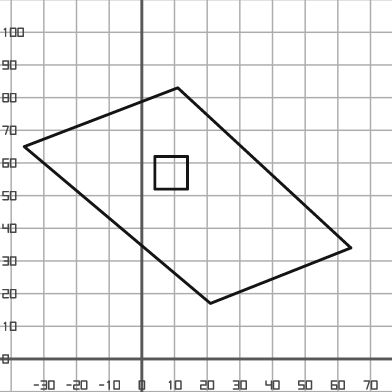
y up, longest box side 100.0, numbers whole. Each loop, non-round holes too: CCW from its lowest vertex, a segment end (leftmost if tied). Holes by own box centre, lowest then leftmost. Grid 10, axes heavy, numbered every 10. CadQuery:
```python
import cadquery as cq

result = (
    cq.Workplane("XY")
    .moveTo(21.0, 17.0)
    .lineTo(64.0, 34.0)
    .lineTo(11.0, 83.0)
    .lineTo(-36.0, 65.0)
    .close()
    .moveTo(4.0, 52.0)
    .lineTo(14.0, 52.0)
    .lineTo(14.0, 62.0)
    .lineTo(4.0, 62.0)
    .close()
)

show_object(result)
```